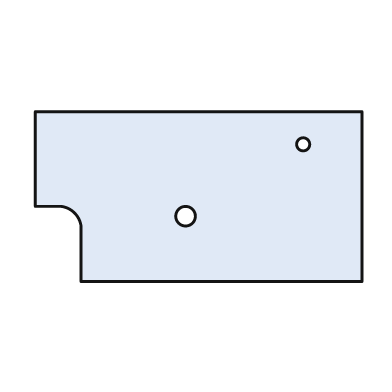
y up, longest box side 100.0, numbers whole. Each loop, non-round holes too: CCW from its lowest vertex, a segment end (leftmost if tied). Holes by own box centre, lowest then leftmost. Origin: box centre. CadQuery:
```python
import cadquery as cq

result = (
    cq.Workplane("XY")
    .moveTo(-36.0, -26.0)
    .lineTo(50.0, -26.0)
    .lineTo(50.0, 26.0)
    .lineTo(-50.0, 26.0)
    .lineTo(-50.0, -3.0)
    .lineTo(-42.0, -3.0)
    .threePointArc((-38.0, -5.0), (-36.0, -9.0))
    .close()
    .moveTo(-4.0, -6.0)
    .circle(3.0)
    .moveTo(32.0, 16.0)
    .circle(2.0)
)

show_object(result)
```